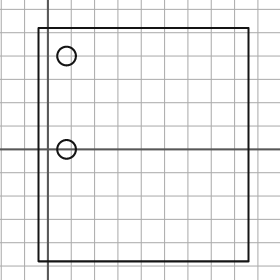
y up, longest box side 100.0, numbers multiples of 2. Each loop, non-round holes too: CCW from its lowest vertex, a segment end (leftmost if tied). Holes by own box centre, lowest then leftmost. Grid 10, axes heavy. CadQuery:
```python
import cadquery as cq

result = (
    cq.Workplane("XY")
    .moveTo(-4.0, -48.0)
    .lineTo(86.0, -48.0)
    .lineTo(86.0, 52.0)
    .lineTo(-4.0, 52.0)
    .close()
    .moveTo(8.0, 0.0)
    .circle(4.0)
    .moveTo(8.0, 40.0)
    .circle(4.0)
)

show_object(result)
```